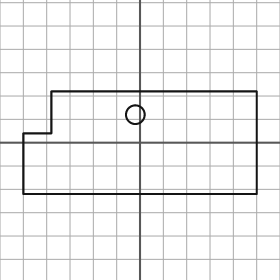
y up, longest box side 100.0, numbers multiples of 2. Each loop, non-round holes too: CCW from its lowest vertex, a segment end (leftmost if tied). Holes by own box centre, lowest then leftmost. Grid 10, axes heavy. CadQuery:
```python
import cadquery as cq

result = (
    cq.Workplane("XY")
    .moveTo(-50.0, -22.0)
    .lineTo(50.0, -22.0)
    .lineTo(50.0, 22.0)
    .lineTo(-38.0, 22.0)
    .lineTo(-38.0, 4.0)
    .lineTo(-50.0, 4.0)
    .close()
    .moveTo(-2.0, 12.0)
    .circle(4.0)
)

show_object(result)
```